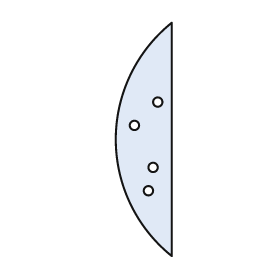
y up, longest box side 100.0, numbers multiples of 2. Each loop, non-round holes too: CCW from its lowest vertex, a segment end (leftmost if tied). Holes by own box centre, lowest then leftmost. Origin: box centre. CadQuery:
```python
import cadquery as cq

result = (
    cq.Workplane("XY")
    .moveTo(12.0, -50.0)
    .lineTo(12.0, 50.0)
    .threePointArc((-12.0, 0.0), (12.0, -50.0))
    .close()
    .moveTo(2.0, -22.0)
    .circle(2.0)
    .moveTo(4.0, -12.0)
    .circle(2.0)
    .moveTo(-4.0, 6.0)
    .circle(2.0)
    .moveTo(6.0, 16.0)
    .circle(2.0)
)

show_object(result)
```